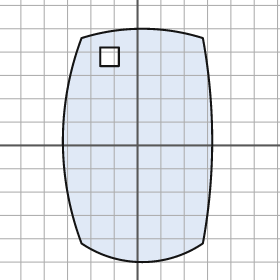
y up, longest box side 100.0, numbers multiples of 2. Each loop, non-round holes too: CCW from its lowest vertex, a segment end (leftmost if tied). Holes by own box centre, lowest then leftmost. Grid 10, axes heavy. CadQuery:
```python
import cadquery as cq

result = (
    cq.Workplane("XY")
    .moveTo(-24.0, -42.0)
    .threePointArc((2.0, -50.0), (28.0, -42.0))
    .threePointArc((32.0, 2.0), (28.0, 46.0))
    .threePointArc((2.0, 50.0), (-24.0, 46.0))
    .threePointArc((-32.0, 2.0), (-24.0, -42.0))
    .close()
    .moveTo(-16.0, 34.0)
    .lineTo(-8.0, 34.0)
    .lineTo(-8.0, 42.0)
    .lineTo(-16.0, 42.0)
    .close()
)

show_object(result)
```